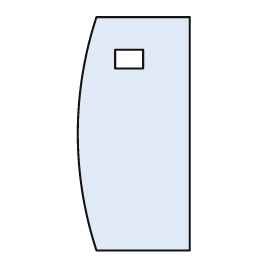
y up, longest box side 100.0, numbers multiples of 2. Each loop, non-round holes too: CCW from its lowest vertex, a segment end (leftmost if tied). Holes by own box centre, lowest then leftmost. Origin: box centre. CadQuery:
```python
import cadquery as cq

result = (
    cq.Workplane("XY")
    .moveTo(-16.0, -50.0)
    .lineTo(24.0, -50.0)
    .lineTo(24.0, 50.0)
    .lineTo(-16.0, 50.0)
    .threePointArc((-24.0, 0.0), (-16.0, -50.0))
    .close()
    .moveTo(-8.0, 28.0)
    .lineTo(4.0, 28.0)
    .lineTo(4.0, 36.0)
    .lineTo(-8.0, 36.0)
    .close()
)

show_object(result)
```